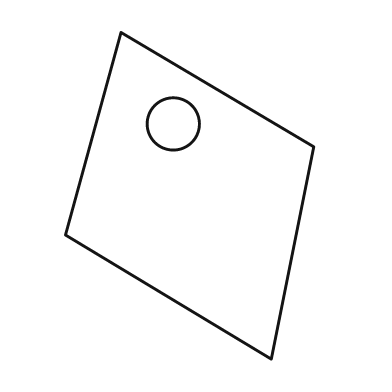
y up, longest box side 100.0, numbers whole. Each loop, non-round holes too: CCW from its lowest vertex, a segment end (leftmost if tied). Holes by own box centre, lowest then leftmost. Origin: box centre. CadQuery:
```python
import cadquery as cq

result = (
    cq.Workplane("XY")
    .moveTo(25.0, -50.0)
    .lineTo(38.0, 15.0)
    .lineTo(-21.0, 50.0)
    .lineTo(-38.0, -12.0)
    .close()
    .moveTo(-5.0, 22.0)
    .circle(8.0)
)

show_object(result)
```